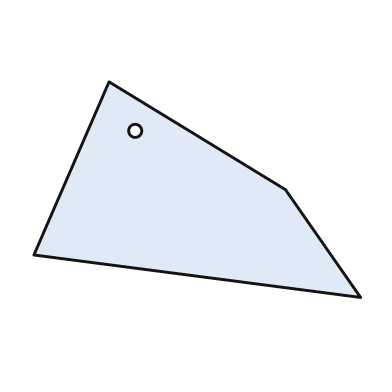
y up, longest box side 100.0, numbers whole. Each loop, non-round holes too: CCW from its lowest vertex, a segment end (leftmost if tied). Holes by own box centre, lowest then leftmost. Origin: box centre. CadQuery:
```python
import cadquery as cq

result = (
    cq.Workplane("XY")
    .moveTo(50.0, -33.0)
    .lineTo(27.0, 0.0)
    .lineTo(-27.0, 33.0)
    .lineTo(-50.0, -20.0)
    .close()
    .moveTo(-19.0, 18.0)
    .circle(2.0)
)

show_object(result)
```